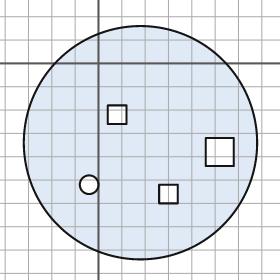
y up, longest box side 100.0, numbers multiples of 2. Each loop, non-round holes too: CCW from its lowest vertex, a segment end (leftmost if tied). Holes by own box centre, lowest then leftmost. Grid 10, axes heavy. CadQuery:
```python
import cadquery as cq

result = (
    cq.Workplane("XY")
    .moveTo(18.0, -34.0)
    .circle(50.0)
    .moveTo(26.0, -60.0)
    .lineTo(34.0, -60.0)
    .lineTo(34.0, -52.0)
    .lineTo(26.0, -52.0)
    .close()
    .moveTo(-4.0, -52.0)
    .circle(4.0)
    .moveTo(46.0, -44.0)
    .lineTo(58.0, -44.0)
    .lineTo(58.0, -32.0)
    .lineTo(46.0, -32.0)
    .close()
    .moveTo(4.0, -26.0)
    .lineTo(12.0, -26.0)
    .lineTo(12.0, -18.0)
    .lineTo(4.0, -18.0)
    .close()
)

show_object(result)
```